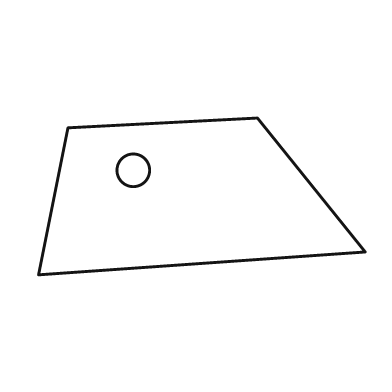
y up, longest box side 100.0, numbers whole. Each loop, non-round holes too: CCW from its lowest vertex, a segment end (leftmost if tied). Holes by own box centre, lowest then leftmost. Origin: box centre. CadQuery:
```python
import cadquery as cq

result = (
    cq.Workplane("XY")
    .moveTo(-50.0, -24.0)
    .lineTo(50.0, -17.0)
    .lineTo(17.0, 24.0)
    .lineTo(-41.0, 21.0)
    .close()
    .moveTo(-21.0, 8.0)
    .circle(5.0)
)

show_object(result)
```